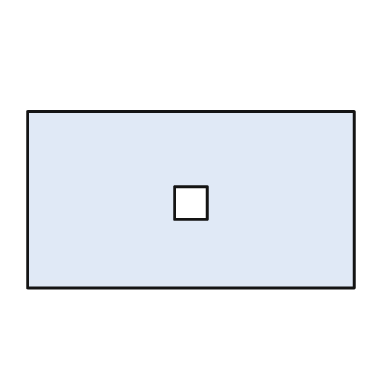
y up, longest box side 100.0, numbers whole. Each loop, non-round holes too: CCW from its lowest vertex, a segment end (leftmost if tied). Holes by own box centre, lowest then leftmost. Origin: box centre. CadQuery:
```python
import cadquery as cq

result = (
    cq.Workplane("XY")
    .moveTo(-50.0, -27.0)
    .lineTo(50.0, -27.0)
    .lineTo(50.0, 27.0)
    .lineTo(-50.0, 27.0)
    .close()
    .moveTo(-5.0, -6.0)
    .lineTo(5.0, -6.0)
    .lineTo(5.0, 4.0)
    .lineTo(-5.0, 4.0)
    .close()
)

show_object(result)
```